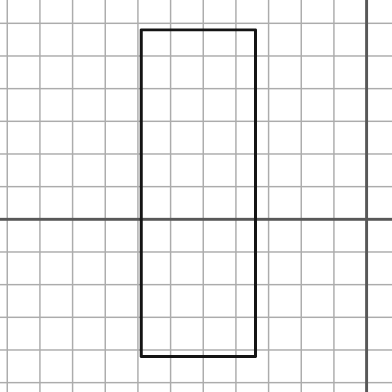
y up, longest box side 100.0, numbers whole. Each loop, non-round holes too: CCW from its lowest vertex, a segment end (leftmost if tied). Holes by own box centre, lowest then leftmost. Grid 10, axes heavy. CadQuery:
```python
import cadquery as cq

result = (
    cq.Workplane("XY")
    .moveTo(-69.0, -42.0)
    .lineTo(-34.0, -42.0)
    .lineTo(-34.0, 58.0)
    .lineTo(-69.0, 58.0)
    .close()
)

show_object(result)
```